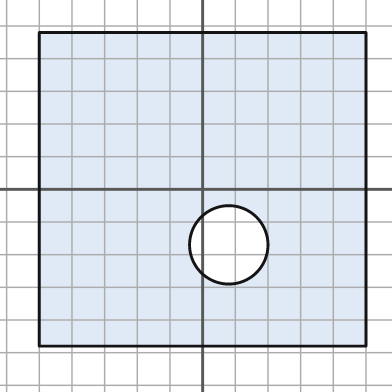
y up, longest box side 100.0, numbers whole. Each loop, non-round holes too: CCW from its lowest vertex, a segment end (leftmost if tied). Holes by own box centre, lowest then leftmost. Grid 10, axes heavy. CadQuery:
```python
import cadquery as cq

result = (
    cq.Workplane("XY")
    .moveTo(-50.0, -48.0)
    .lineTo(50.0, -48.0)
    .lineTo(50.0, 48.0)
    .lineTo(-50.0, 48.0)
    .close()
    .moveTo(8.0, -17.0)
    .circle(12.0)
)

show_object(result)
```